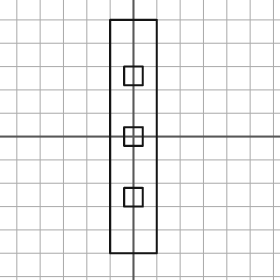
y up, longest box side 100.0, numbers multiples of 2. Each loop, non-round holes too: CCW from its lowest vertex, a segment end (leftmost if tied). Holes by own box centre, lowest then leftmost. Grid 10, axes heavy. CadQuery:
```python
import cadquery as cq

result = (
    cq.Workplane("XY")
    .moveTo(-10.0, -50.0)
    .lineTo(10.0, -50.0)
    .lineTo(10.0, 50.0)
    .lineTo(-10.0, 50.0)
    .close()
    .moveTo(-4.0, -30.0)
    .lineTo(4.0, -30.0)
    .lineTo(4.0, -22.0)
    .lineTo(-4.0, -22.0)
    .close()
    .moveTo(-4.0, -4.0)
    .lineTo(4.0, -4.0)
    .lineTo(4.0, 4.0)
    .lineTo(-4.0, 4.0)
    .close()
    .moveTo(-4.0, 22.0)
    .lineTo(4.0, 22.0)
    .lineTo(4.0, 30.0)
    .lineTo(-4.0, 30.0)
    .close()
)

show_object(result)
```